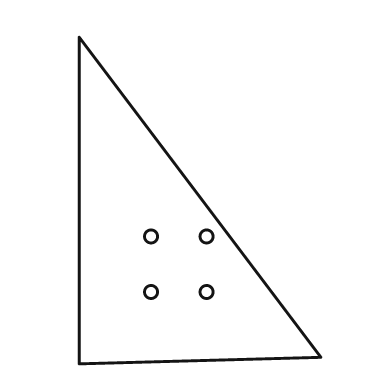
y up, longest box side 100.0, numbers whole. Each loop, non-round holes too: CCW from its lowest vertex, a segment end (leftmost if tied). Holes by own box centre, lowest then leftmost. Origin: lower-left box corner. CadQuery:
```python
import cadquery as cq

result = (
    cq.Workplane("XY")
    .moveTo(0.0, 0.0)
    .lineTo(74.0, 2.0)
    .lineTo(0.0, 100.0)
    .close()
    .moveTo(22.0, 22.0)
    .circle(2.0)
    .moveTo(39.0, 22.0)
    .circle(2.0)
    .moveTo(22.0, 39.0)
    .circle(2.0)
    .moveTo(39.0, 39.0)
    .circle(2.0)
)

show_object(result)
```